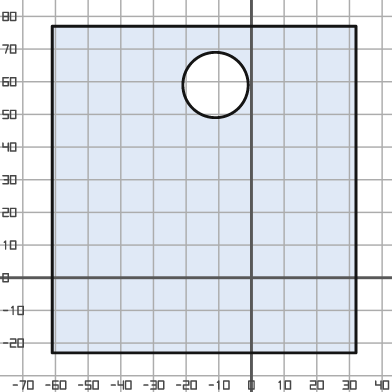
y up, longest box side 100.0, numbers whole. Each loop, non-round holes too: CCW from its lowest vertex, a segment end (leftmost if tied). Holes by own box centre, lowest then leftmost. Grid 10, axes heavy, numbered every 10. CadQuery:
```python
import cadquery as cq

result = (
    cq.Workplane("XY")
    .moveTo(-61.0, -23.0)
    .lineTo(32.0, -23.0)
    .lineTo(32.0, 77.0)
    .lineTo(-61.0, 77.0)
    .close()
    .moveTo(-11.0, 59.0)
    .circle(10.0)
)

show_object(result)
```